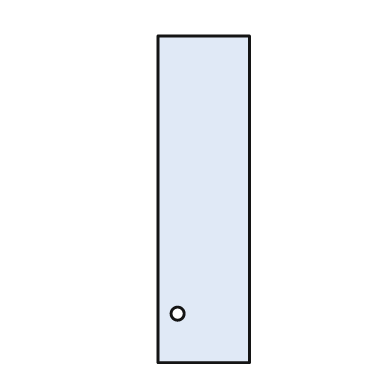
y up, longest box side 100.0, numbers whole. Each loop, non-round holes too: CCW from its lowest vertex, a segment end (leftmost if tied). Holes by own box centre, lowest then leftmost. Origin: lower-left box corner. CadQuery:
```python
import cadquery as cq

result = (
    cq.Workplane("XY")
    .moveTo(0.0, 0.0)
    .lineTo(28.0, 0.0)
    .lineTo(28.0, 100.0)
    .lineTo(0.0, 100.0)
    .close()
    .moveTo(6.0, 15.0)
    .circle(2.0)
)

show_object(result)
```